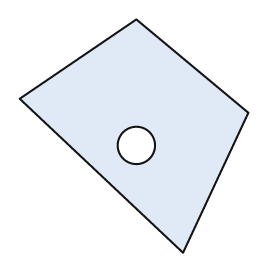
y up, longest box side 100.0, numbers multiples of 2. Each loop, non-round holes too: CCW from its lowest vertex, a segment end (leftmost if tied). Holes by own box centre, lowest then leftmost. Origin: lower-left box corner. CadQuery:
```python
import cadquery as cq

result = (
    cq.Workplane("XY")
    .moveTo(70.0, 0.0)
    .lineTo(98.0, 60.0)
    .lineTo(50.0, 100.0)
    .lineTo(0.0, 66.0)
    .close()
    .moveTo(50.0, 46.0)
    .circle(8.0)
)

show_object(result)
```